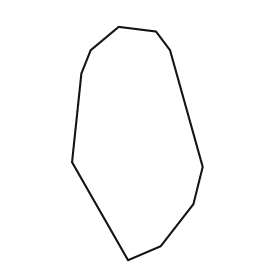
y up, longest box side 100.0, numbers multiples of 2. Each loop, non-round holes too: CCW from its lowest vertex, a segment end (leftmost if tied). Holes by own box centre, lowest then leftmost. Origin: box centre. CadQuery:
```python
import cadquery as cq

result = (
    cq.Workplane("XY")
    .moveTo(-4.0, -50.0)
    .lineTo(10.0, -44.0)
    .lineTo(24.0, -26.0)
    .lineTo(28.0, -10.0)
    .lineTo(14.0, 40.0)
    .lineTo(8.0, 48.0)
    .lineTo(-8.0, 50.0)
    .lineTo(-20.0, 40.0)
    .lineTo(-24.0, 30.0)
    .lineTo(-28.0, -8.0)
    .close()
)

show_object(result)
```